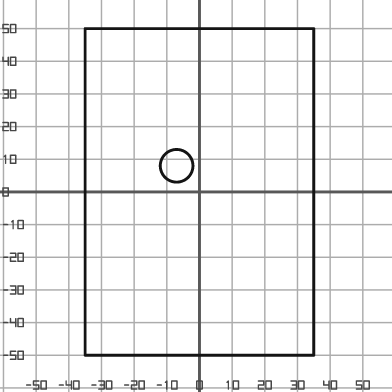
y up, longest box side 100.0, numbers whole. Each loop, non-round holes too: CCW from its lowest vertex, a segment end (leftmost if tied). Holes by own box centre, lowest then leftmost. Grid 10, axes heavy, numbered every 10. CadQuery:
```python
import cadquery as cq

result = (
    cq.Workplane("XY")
    .moveTo(-35.0, -50.0)
    .lineTo(35.0, -50.0)
    .lineTo(35.0, 50.0)
    .lineTo(-35.0, 50.0)
    .close()
    .moveTo(-7.0, 8.0)
    .circle(5.0)
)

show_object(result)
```